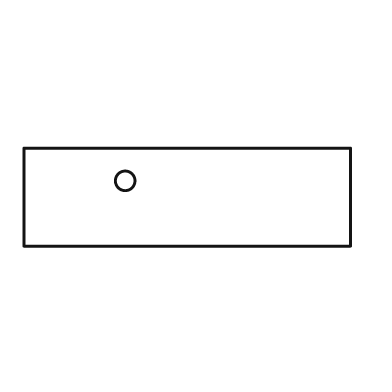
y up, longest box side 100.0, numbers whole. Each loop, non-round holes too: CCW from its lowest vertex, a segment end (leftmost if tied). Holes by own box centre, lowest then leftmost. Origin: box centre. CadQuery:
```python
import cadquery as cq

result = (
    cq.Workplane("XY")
    .moveTo(-50.0, -15.0)
    .lineTo(50.0, -15.0)
    .lineTo(50.0, 15.0)
    .lineTo(-50.0, 15.0)
    .close()
    .moveTo(-19.0, 5.0)
    .circle(3.0)
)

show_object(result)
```